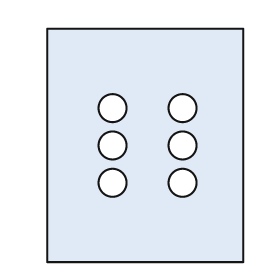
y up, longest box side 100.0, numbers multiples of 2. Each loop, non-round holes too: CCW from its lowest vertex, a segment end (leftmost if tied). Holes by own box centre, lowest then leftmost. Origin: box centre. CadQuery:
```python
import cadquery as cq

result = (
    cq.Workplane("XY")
    .moveTo(-42.0, -50.0)
    .lineTo(42.0, -50.0)
    .lineTo(42.0, 50.0)
    .lineTo(-42.0, 50.0)
    .close()
    .moveTo(-14.0, -16.0)
    .circle(6.0)
    .moveTo(16.0, -16.0)
    .circle(6.0)
    .moveTo(-14.0, 0.0)
    .circle(6.0)
    .moveTo(16.0, 0.0)
    .circle(6.0)
    .moveTo(-14.0, 16.0)
    .circle(6.0)
    .moveTo(16.0, 16.0)
    .circle(6.0)
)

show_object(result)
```